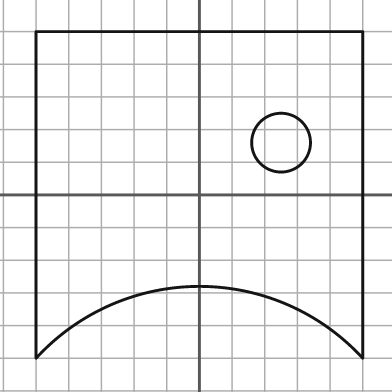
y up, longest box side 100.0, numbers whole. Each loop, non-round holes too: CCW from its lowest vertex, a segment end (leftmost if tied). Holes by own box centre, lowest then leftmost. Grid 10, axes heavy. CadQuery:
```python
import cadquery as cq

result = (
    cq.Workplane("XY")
    .moveTo(-50.0, -50.0)
    .threePointArc((0.0, -28.0), (50.0, -50.0))
    .lineTo(50.0, 50.0)
    .lineTo(-50.0, 50.0)
    .close()
    .moveTo(25.0, 16.0)
    .circle(9.0)
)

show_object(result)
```